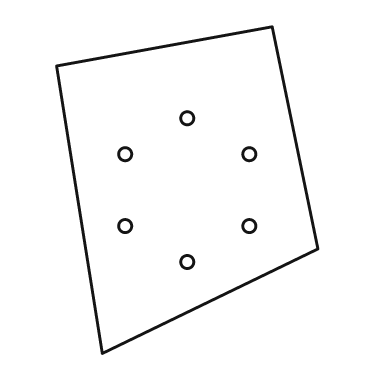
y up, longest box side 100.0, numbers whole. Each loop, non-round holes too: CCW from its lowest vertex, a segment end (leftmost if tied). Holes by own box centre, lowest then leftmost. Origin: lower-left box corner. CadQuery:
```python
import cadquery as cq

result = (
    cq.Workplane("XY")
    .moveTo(14.0, 0.0)
    .lineTo(80.0, 32.0)
    .lineTo(66.0, 100.0)
    .lineTo(0.0, 88.0)
    .close()
    .moveTo(40.0, 28.0)
    .circle(2.0)
    .moveTo(21.0, 39.0)
    .circle(2.0)
    .moveTo(59.0, 39.0)
    .circle(2.0)
    .moveTo(21.0, 61.0)
    .circle(2.0)
    .moveTo(59.0, 61.0)
    .circle(2.0)
    .moveTo(40.0, 72.0)
    .circle(2.0)
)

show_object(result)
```